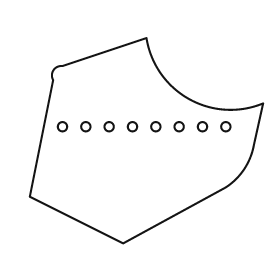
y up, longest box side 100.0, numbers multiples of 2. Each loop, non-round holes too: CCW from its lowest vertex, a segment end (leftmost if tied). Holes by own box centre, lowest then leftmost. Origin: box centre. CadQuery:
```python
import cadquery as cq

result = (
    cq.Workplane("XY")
    .moveTo(-10.0, -44.0)
    .lineTo(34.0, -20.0)
    .threePointArc((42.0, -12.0), (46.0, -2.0))
    .lineTo(50.0, 16.0)
    .threePointArc((18.0, 18.0), (0.0, 44.0))
    .lineTo(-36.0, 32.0)
    .threePointArc((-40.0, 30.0), (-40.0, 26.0))
    .lineTo(-50.0, -24.0)
    .close()
    .moveTo(-36.0, 6.0)
    .circle(2.0)
    .moveTo(-26.0, 6.0)
    .circle(2.0)
    .moveTo(-16.0, 6.0)
    .circle(2.0)
    .moveTo(-6.0, 6.0)
    .circle(2.0)
    .moveTo(4.0, 6.0)
    .circle(2.0)
    .moveTo(14.0, 6.0)
    .circle(2.0)
    .moveTo(24.0, 6.0)
    .circle(2.0)
    .moveTo(34.0, 6.0)
    .circle(2.0)
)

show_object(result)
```